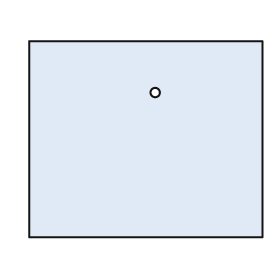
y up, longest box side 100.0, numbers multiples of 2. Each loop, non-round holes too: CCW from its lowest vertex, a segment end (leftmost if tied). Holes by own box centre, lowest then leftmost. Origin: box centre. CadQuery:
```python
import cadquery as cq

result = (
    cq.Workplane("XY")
    .moveTo(-50.0, -42.0)
    .lineTo(50.0, -42.0)
    .lineTo(50.0, 42.0)
    .lineTo(-50.0, 42.0)
    .close()
    .moveTo(4.0, 20.0)
    .circle(2.0)
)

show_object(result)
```